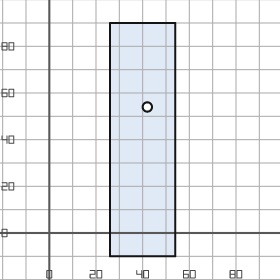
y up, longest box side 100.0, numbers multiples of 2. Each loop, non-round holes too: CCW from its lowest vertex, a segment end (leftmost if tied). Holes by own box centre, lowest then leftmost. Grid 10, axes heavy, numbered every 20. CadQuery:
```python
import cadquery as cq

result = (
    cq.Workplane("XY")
    .moveTo(26.0, -10.0)
    .lineTo(54.0, -10.0)
    .lineTo(54.0, 90.0)
    .lineTo(26.0, 90.0)
    .close()
    .moveTo(42.0, 54.0)
    .circle(2.0)
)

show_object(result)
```